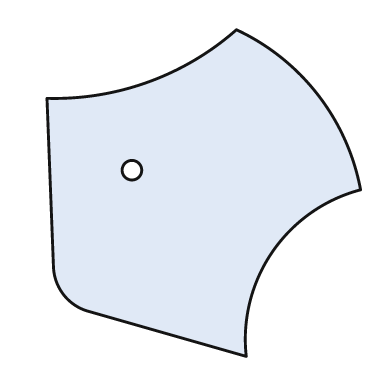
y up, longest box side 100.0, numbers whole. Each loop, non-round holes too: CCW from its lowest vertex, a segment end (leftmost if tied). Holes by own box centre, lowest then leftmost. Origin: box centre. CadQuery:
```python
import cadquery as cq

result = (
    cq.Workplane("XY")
    .moveTo(13.0, -50.0)
    .threePointArc((21.0, -18.0), (48.0, 1.0))
    .threePointArc((35.0, 30.0), (10.0, 50.0))
    .threePointArc((-17.0, 34.0), (-48.0, 29.0))
    .lineTo(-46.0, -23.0)
    .threePointArc((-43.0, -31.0), (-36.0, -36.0))
    .close()
    .moveTo(-22.0, 7.0)
    .circle(3.0)
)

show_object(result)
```